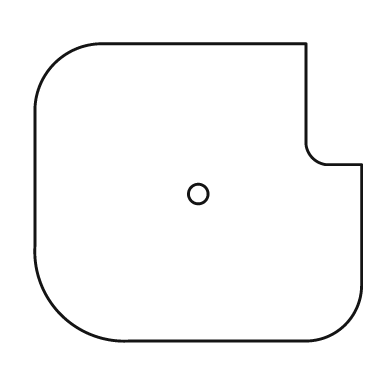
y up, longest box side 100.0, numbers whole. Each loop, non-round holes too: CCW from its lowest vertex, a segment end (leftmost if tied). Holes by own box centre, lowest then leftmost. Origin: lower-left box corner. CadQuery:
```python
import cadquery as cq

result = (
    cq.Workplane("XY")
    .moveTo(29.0, 0.0)
    .lineTo(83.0, 0.0)
    .threePointArc((95.0, 5.0), (100.0, 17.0))
    .lineTo(100.0, 54.0)
    .lineTo(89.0, 54.0)
    .threePointArc((85.0, 56.0), (83.0, 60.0))
    .lineTo(83.0, 91.0)
    .lineTo(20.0, 91.0)
    .threePointArc((6.0, 85.0), (0.0, 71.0))
    .lineTo(0.0, 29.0)
    .threePointArc((8.0, 8.0), (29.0, 0.0))
    .close()
    .moveTo(50.0, 45.0)
    .circle(3.0)
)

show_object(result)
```